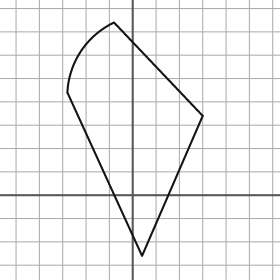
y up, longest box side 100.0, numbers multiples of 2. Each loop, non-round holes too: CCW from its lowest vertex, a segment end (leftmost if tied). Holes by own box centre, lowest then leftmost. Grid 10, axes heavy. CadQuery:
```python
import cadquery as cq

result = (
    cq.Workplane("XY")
    .moveTo(4.0, -26.0)
    .lineTo(30.0, 34.0)
    .lineTo(-8.0, 74.0)
    .threePointArc((-22.0, 62.0), (-28.0, 44.0))
    .close()
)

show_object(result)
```